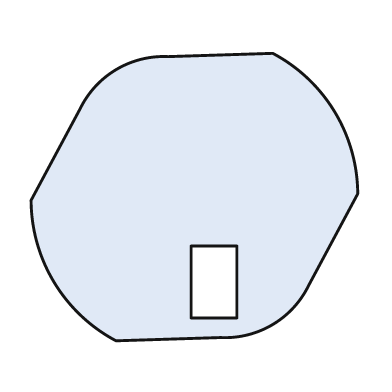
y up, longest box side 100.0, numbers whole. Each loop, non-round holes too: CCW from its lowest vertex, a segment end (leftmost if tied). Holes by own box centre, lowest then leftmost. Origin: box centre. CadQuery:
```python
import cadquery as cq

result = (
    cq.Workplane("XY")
    .moveTo(-24.0, -44.0)
    .lineTo(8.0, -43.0)
    .threePointArc((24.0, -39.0), (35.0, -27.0))
    .lineTo(50.0, 1.0)
    .threePointArc((43.0, 26.0), (24.0, 44.0))
    .lineTo(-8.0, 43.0)
    .threePointArc((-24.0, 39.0), (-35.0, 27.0))
    .lineTo(-50.0, -1.0)
    .threePointArc((-43.0, -26.0), (-24.0, -44.0))
    .close()
    .moveTo(-1.0, -37.0)
    .lineTo(13.0, -37.0)
    .lineTo(13.0, -15.0)
    .lineTo(-1.0, -15.0)
    .close()
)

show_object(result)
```